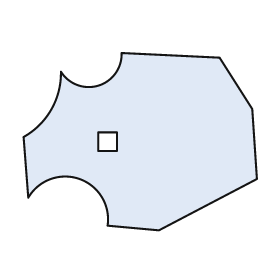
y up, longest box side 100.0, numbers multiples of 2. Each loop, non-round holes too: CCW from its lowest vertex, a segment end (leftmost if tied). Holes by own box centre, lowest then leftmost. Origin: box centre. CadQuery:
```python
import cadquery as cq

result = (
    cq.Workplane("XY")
    .moveTo(8.0, -38.0)
    .lineTo(50.0, -16.0)
    .lineTo(48.0, 14.0)
    .lineTo(34.0, 36.0)
    .lineTo(-8.0, 38.0)
    .threePointArc((-18.0, 24.0), (-34.0, 30.0))
    .threePointArc((-38.0, 14.0), (-50.0, 2.0))
    .lineTo(-48.0, -24.0)
    .threePointArc((-26.0, -16.0), (-14.0, -36.0))
    .close()
    .moveTo(-18.0, -4.0)
    .lineTo(-10.0, -4.0)
    .lineTo(-10.0, 4.0)
    .lineTo(-18.0, 4.0)
    .close()
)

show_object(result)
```